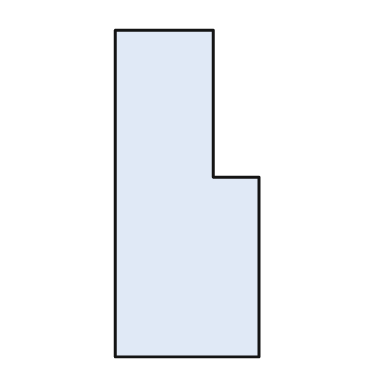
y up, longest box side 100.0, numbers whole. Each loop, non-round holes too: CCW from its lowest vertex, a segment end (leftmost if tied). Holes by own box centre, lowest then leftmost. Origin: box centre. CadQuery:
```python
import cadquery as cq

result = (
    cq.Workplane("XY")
    .moveTo(-22.0, -50.0)
    .lineTo(22.0, -50.0)
    .lineTo(22.0, 5.0)
    .lineTo(8.0, 5.0)
    .lineTo(8.0, 50.0)
    .lineTo(-22.0, 50.0)
    .close()
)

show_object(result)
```